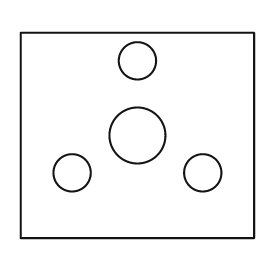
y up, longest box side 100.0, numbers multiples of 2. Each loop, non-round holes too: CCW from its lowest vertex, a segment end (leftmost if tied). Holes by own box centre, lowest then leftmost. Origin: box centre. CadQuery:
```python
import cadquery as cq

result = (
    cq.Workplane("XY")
    .moveTo(-50.0, -44.0)
    .lineTo(50.0, -44.0)
    .lineTo(50.0, 44.0)
    .lineTo(-50.0, 44.0)
    .close()
    .moveTo(-28.0, -16.0)
    .circle(8.0)
    .moveTo(28.0, -16.0)
    .circle(8.0)
    .moveTo(0.0, 0.0)
    .circle(12.0)
    .moveTo(0.0, 32.0)
    .circle(8.0)
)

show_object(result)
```